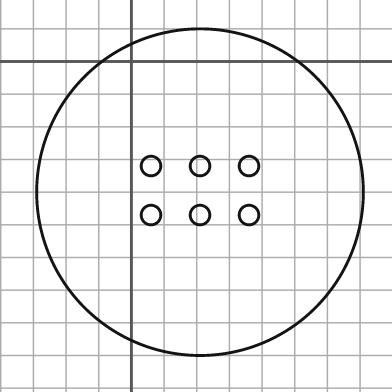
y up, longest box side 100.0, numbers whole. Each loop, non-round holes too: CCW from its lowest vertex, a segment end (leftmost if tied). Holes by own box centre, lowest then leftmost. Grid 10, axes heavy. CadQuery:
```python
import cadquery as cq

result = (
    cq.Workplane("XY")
    .moveTo(21.0, -40.0)
    .circle(50.0)
    .moveTo(6.0, -47.0)
    .circle(3.0)
    .moveTo(21.0, -47.0)
    .circle(3.0)
    .moveTo(36.0, -47.0)
    .circle(3.0)
    .moveTo(6.0, -32.0)
    .circle(3.0)
    .moveTo(21.0, -32.0)
    .circle(3.0)
    .moveTo(36.0, -32.0)
    .circle(3.0)
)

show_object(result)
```